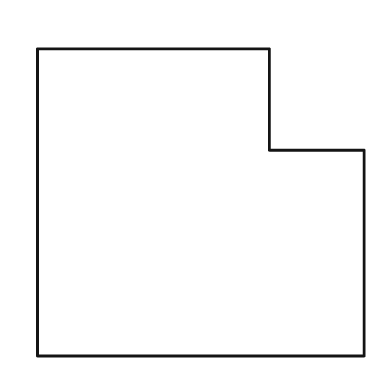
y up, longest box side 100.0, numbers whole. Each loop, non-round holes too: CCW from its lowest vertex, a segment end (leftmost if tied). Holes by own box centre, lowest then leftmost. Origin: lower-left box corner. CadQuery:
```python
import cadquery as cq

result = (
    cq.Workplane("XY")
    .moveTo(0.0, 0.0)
    .lineTo(100.0, 0.0)
    .lineTo(100.0, 63.0)
    .lineTo(71.0, 63.0)
    .lineTo(71.0, 94.0)
    .lineTo(0.0, 94.0)
    .close()
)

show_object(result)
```